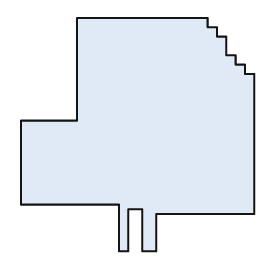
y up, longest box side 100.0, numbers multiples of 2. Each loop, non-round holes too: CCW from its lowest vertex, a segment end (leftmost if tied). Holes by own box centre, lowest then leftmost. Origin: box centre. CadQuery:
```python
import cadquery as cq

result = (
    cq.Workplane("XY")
    .moveTo(-8.0, -50.0)
    .lineTo(-4.0, -50.0)
    .lineTo(-4.0, -32.0)
    .lineTo(2.0, -32.0)
    .lineTo(2.0, -50.0)
    .lineTo(8.0, -50.0)
    .lineTo(8.0, -34.0)
    .lineTo(50.0, -34.0)
    .lineTo(50.0, 26.0)
    .lineTo(46.0, 26.0)
    .lineTo(46.0, 30.0)
    .lineTo(42.0, 30.0)
    .lineTo(42.0, 34.0)
    .lineTo(38.0, 34.0)
    .lineTo(38.0, 42.0)
    .lineTo(34.0, 42.0)
    .lineTo(34.0, 46.0)
    .lineTo(30.0, 46.0)
    .lineTo(30.0, 50.0)
    .lineTo(-26.0, 50.0)
    .lineTo(-26.0, 6.0)
    .lineTo(-50.0, 6.0)
    .lineTo(-50.0, -30.0)
    .lineTo(-8.0, -30.0)
    .close()
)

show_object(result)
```